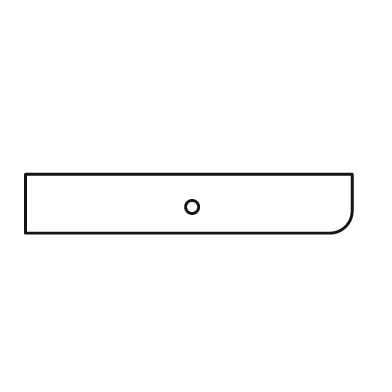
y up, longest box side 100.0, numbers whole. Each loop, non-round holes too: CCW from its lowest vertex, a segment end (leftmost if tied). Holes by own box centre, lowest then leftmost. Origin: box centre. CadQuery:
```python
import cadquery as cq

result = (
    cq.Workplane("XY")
    .moveTo(-50.0, -9.0)
    .lineTo(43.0, -9.0)
    .threePointArc((48.0, -7.0), (50.0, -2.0))
    .lineTo(50.0, 9.0)
    .lineTo(-50.0, 9.0)
    .close()
    .moveTo(1.0, -1.0)
    .circle(2.0)
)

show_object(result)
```